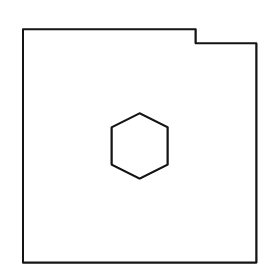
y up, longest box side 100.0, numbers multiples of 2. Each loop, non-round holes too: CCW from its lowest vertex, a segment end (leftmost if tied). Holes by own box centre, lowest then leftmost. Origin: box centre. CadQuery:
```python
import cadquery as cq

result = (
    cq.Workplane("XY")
    .moveTo(-50.0, -50.0)
    .lineTo(50.0, -50.0)
    .lineTo(50.0, 44.0)
    .lineTo(24.0, 44.0)
    .lineTo(24.0, 50.0)
    .lineTo(-50.0, 50.0)
    .close()
    .moveTo(0.0, -14.0)
    .lineTo(12.0, -8.0)
    .lineTo(12.0, 8.0)
    .lineTo(0.0, 14.0)
    .lineTo(-12.0, 8.0)
    .lineTo(-12.0, -8.0)
    .close()
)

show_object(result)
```